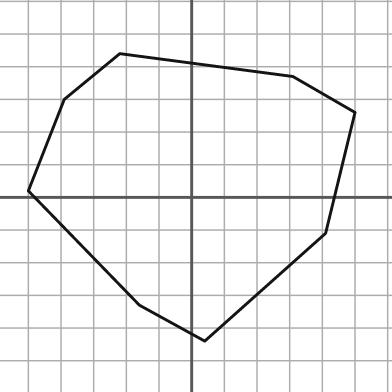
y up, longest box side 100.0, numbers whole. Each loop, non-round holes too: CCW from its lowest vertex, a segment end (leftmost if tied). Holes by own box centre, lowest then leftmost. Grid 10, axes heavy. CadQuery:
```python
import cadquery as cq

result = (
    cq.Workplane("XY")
    .moveTo(4.0, -44.0)
    .lineTo(41.0, -11.0)
    .lineTo(50.0, 26.0)
    .lineTo(31.0, 37.0)
    .lineTo(-22.0, 44.0)
    .lineTo(-39.0, 30.0)
    .lineTo(-50.0, 2.0)
    .lineTo(-16.0, -33.0)
    .close()
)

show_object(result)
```